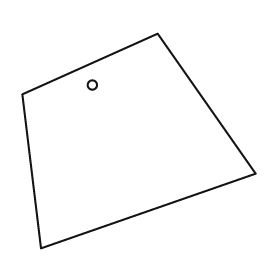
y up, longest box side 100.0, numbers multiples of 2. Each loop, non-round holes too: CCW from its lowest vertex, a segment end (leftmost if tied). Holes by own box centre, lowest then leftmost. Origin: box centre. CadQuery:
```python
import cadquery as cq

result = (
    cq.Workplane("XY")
    .moveTo(-42.0, -46.0)
    .lineTo(50.0, -14.0)
    .lineTo(8.0, 46.0)
    .lineTo(-50.0, 20.0)
    .close()
    .moveTo(-20.0, 24.0)
    .circle(2.0)
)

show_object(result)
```